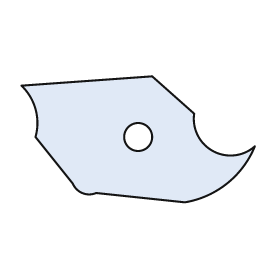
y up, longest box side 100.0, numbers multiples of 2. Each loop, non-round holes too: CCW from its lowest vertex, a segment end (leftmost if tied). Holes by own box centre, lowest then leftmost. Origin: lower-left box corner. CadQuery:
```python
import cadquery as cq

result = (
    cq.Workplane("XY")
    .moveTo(70.0, 0.0)
    .threePointArc((88.0, 8.0), (100.0, 24.0))
    .threePointArc((82.0, 22.0), (74.0, 38.0))
    .lineTo(56.0, 54.0)
    .lineTo(0.0, 50.0)
    .threePointArc((6.0, 40.0), (6.0, 28.0))
    .lineTo(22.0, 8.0)
    .threePointArc((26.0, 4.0), (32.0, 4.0))
    .close()
    .moveTo(50.0, 28.0)
    .circle(6.0)
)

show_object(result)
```